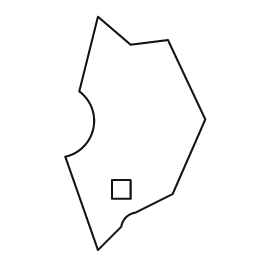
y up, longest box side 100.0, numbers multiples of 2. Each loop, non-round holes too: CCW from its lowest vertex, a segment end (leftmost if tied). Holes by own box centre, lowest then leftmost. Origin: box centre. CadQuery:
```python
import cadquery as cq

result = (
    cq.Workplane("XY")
    .moveTo(-16.0, -50.0)
    .lineTo(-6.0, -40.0)
    .threePointArc((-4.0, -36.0), (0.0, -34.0))
    .lineTo(16.0, -26.0)
    .lineTo(30.0, 6.0)
    .lineTo(14.0, 40.0)
    .lineTo(-2.0, 38.0)
    .lineTo(-16.0, 50.0)
    .lineTo(-24.0, 18.0)
    .threePointArc((-18.0, 2.0), (-30.0, -10.0))
    .close()
    .moveTo(-10.0, -28.0)
    .lineTo(-2.0, -28.0)
    .lineTo(-2.0, -20.0)
    .lineTo(-10.0, -20.0)
    .close()
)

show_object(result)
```